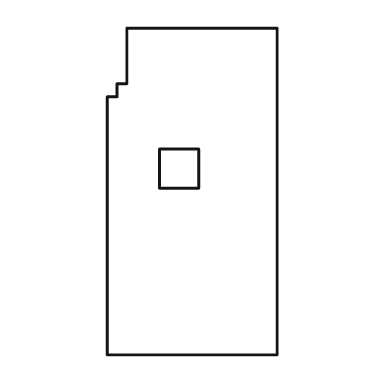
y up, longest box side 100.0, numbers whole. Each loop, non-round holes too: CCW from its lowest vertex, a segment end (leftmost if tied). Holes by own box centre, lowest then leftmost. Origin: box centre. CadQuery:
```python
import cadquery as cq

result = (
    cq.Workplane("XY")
    .moveTo(-26.0, -50.0)
    .lineTo(26.0, -50.0)
    .lineTo(26.0, 50.0)
    .lineTo(-20.0, 50.0)
    .lineTo(-20.0, 33.0)
    .lineTo(-23.0, 33.0)
    .lineTo(-23.0, 29.0)
    .lineTo(-26.0, 29.0)
    .close()
    .moveTo(-10.0, 1.0)
    .lineTo(2.0, 1.0)
    .lineTo(2.0, 13.0)
    .lineTo(-10.0, 13.0)
    .close()
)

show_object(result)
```